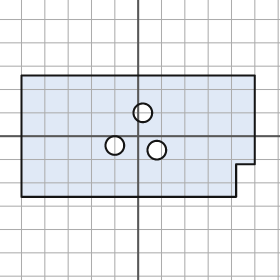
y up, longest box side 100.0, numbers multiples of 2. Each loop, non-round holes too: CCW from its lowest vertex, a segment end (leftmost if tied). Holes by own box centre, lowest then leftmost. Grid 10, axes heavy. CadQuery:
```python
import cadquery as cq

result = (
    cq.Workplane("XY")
    .moveTo(-50.0, -26.0)
    .lineTo(42.0, -26.0)
    .lineTo(42.0, -12.0)
    .lineTo(50.0, -12.0)
    .lineTo(50.0, 26.0)
    .lineTo(-50.0, 26.0)
    .close()
    .moveTo(8.0, -6.0)
    .circle(4.0)
    .moveTo(-10.0, -4.0)
    .circle(4.0)
    .moveTo(2.0, 10.0)
    .circle(4.0)
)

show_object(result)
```